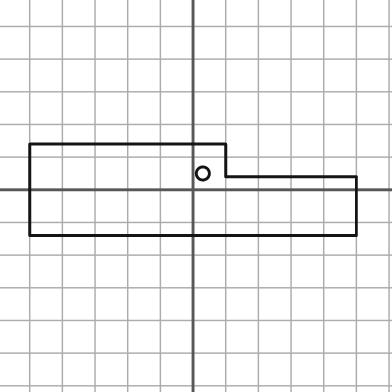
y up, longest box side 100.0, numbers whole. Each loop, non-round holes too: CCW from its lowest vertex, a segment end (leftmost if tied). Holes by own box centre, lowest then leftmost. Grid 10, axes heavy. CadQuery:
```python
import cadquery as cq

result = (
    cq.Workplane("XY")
    .moveTo(-50.0, -14.0)
    .lineTo(50.0, -14.0)
    .lineTo(50.0, 4.0)
    .lineTo(10.0, 4.0)
    .lineTo(10.0, 14.0)
    .lineTo(-50.0, 14.0)
    .close()
    .moveTo(3.0, 5.0)
    .circle(2.0)
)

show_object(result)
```